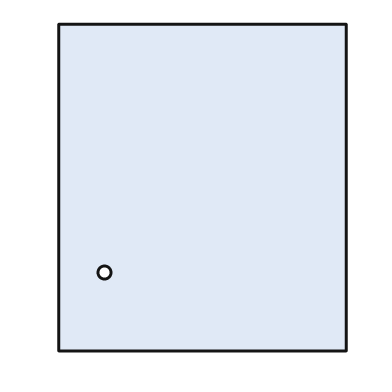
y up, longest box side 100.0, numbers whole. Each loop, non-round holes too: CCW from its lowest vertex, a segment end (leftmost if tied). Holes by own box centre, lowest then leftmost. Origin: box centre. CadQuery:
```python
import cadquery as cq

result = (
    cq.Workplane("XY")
    .moveTo(-44.0, -50.0)
    .lineTo(44.0, -50.0)
    .lineTo(44.0, 50.0)
    .lineTo(-44.0, 50.0)
    .close()
    .moveTo(-30.0, -26.0)
    .circle(2.0)
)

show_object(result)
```